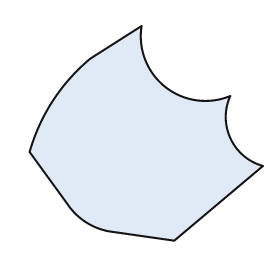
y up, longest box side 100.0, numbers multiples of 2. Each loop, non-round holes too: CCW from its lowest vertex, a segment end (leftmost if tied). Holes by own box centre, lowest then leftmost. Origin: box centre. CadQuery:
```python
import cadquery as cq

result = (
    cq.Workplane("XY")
    .moveTo(12.0, -46.0)
    .lineTo(50.0, -14.0)
    .threePointArc((36.0, -2.0), (36.0, 16.0))
    .threePointArc((8.0, 20.0), (-2.0, 46.0))
    .lineTo(-24.0, 32.0)
    .threePointArc((-40.0, 14.0), (-50.0, -8.0))
    .lineTo(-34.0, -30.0)
    .threePointArc((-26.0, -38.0), (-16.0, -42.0))
    .close()
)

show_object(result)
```